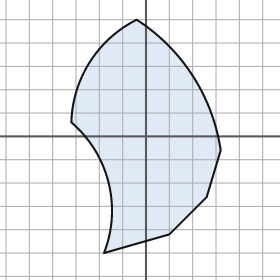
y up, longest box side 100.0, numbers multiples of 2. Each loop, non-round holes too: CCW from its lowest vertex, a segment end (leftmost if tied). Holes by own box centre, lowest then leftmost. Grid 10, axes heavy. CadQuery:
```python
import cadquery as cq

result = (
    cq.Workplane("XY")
    .moveTo(-18.0, -50.0)
    .lineTo(10.0, -42.0)
    .lineTo(26.0, -26.0)
    .lineTo(32.0, -6.0)
    .threePointArc((20.0, 26.0), (-4.0, 50.0))
    .threePointArc((-24.0, 32.0), (-32.0, 6.0))
    .threePointArc((-16.0, -20.0), (-18.0, -50.0))
    .close()
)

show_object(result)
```